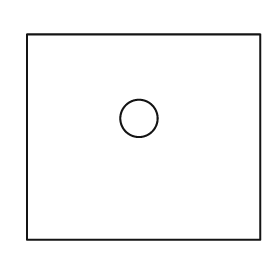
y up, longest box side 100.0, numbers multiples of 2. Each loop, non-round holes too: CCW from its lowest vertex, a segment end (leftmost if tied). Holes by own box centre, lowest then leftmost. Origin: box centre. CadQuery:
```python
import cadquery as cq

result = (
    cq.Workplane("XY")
    .moveTo(-50.0, -44.0)
    .lineTo(50.0, -44.0)
    .lineTo(50.0, 44.0)
    .lineTo(-50.0, 44.0)
    .close()
    .moveTo(-2.0, 8.0)
    .circle(8.0)
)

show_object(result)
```